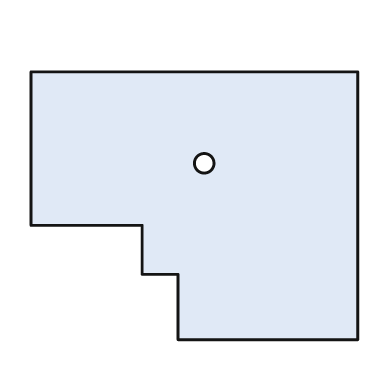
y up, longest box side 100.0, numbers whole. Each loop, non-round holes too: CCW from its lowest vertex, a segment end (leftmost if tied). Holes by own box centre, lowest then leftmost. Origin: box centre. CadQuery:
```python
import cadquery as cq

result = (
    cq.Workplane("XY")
    .moveTo(-5.0, -41.0)
    .lineTo(50.0, -41.0)
    .lineTo(50.0, 41.0)
    .lineTo(-50.0, 41.0)
    .lineTo(-50.0, -6.0)
    .lineTo(-16.0, -6.0)
    .lineTo(-16.0, -21.0)
    .lineTo(-5.0, -21.0)
    .close()
    .moveTo(3.0, 13.0)
    .circle(3.0)
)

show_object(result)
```